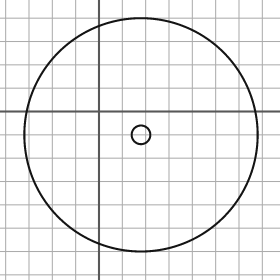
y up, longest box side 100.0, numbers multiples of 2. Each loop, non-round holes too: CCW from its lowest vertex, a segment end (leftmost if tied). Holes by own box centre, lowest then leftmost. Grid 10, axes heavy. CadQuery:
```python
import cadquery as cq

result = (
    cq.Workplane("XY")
    .moveTo(18.0, -10.0)
    .circle(50.0)
    .moveTo(18.0, -10.0)
    .circle(4.0)
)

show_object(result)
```